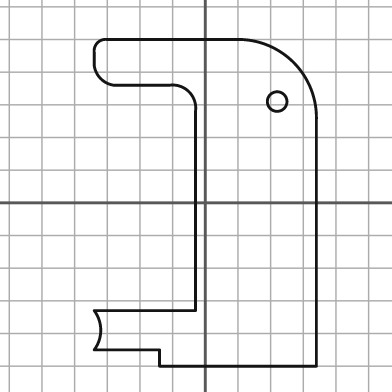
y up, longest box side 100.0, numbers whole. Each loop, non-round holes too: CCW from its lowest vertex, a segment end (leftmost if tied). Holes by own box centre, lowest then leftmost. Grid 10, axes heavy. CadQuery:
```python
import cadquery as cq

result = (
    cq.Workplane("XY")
    .moveTo(-14.0, -50.0)
    .lineTo(34.0, -50.0)
    .lineTo(34.0, 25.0)
    .threePointArc((27.0, 43.0), (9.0, 50.0))
    .lineTo(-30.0, 50.0)
    .threePointArc((-33.0, 49.0), (-34.0, 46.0))
    .lineTo(-34.0, 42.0)
    .threePointArc((-32.0, 38.0), (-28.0, 36.0))
    .lineTo(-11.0, 36.0)
    .threePointArc((-5.0, 34.0), (-3.0, 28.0))
    .lineTo(-3.0, -33.0)
    .lineTo(-34.0, -33.0)
    .threePointArc((-32.0, -39.0), (-34.0, -45.0))
    .lineTo(-14.0, -45.0)
    .close()
    .moveTo(22.0, 31.0)
    .circle(3.0)
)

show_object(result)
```